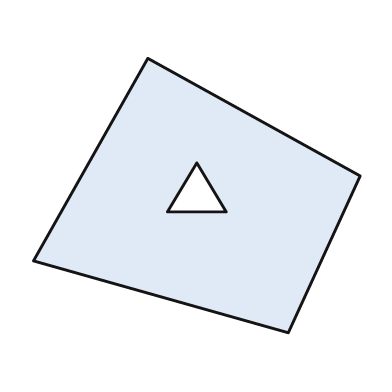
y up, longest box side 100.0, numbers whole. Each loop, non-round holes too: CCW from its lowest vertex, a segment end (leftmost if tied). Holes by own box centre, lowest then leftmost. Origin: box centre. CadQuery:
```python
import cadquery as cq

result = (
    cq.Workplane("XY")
    .moveTo(28.0, -42.0)
    .lineTo(50.0, 6.0)
    .lineTo(-15.0, 42.0)
    .lineTo(-50.0, -20.0)
    .close()
    .moveTo(-9.0, -5.0)
    .lineTo(9.0, -5.0)
    .lineTo(0.0, 10.0)
    .close()
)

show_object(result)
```